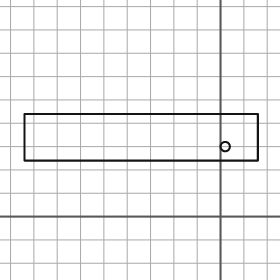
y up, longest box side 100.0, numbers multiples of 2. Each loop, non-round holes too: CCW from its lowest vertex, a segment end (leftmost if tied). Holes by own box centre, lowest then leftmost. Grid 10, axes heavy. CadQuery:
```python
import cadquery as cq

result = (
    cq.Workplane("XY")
    .moveTo(-84.0, 24.0)
    .lineTo(16.0, 24.0)
    .lineTo(16.0, 44.0)
    .lineTo(-84.0, 44.0)
    .close()
    .moveTo(2.0, 30.0)
    .circle(2.0)
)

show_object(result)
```